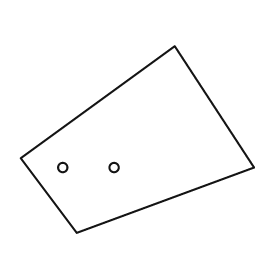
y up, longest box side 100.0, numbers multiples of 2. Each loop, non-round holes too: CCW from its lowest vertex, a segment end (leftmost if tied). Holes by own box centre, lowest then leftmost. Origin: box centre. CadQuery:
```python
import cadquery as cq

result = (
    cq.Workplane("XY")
    .moveTo(-26.0, -40.0)
    .lineTo(50.0, -12.0)
    .lineTo(16.0, 40.0)
    .lineTo(-50.0, -8.0)
    .close()
    .moveTo(-32.0, -12.0)
    .circle(2.0)
    .moveTo(-10.0, -12.0)
    .circle(2.0)
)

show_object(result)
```